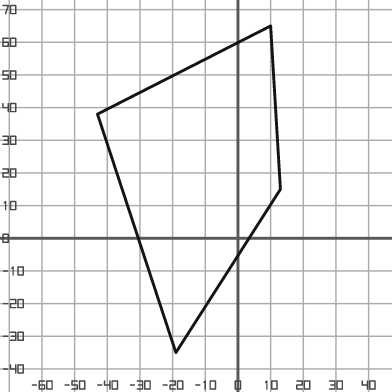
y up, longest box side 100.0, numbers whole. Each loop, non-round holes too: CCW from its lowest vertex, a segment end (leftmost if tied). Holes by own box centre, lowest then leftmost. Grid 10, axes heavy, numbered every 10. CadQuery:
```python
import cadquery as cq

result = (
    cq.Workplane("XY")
    .moveTo(-19.0, -35.0)
    .lineTo(13.0, 15.0)
    .lineTo(10.0, 65.0)
    .lineTo(-43.0, 38.0)
    .close()
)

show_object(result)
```